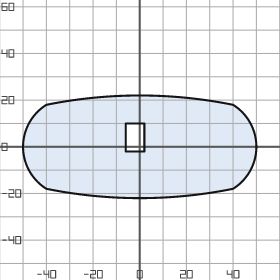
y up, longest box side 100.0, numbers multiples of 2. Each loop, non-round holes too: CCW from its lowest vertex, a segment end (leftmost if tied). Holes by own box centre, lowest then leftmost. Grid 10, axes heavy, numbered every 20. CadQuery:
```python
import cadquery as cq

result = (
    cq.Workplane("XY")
    .moveTo(-40.0, -18.0)
    .threePointArc((0.0, -22.0), (40.0, -18.0))
    .threePointArc((50.0, 0.0), (40.0, 18.0))
    .threePointArc((0.0, 22.0), (-40.0, 18.0))
    .threePointArc((-50.0, 0.0), (-40.0, -18.0))
    .close()
    .moveTo(-6.0, -2.0)
    .lineTo(2.0, -2.0)
    .lineTo(2.0, 10.0)
    .lineTo(-6.0, 10.0)
    .close()
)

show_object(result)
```